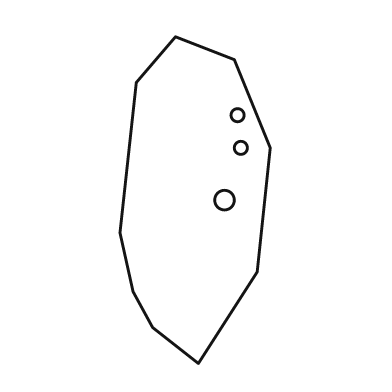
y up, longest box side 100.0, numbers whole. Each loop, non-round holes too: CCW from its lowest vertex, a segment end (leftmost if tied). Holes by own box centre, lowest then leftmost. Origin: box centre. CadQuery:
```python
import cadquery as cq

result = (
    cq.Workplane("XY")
    .moveTo(1.0, -50.0)
    .lineTo(19.0, -22.0)
    .lineTo(23.0, 16.0)
    .lineTo(12.0, 43.0)
    .lineTo(-6.0, 50.0)
    .lineTo(-18.0, 36.0)
    .lineTo(-23.0, -10.0)
    .lineTo(-19.0, -28.0)
    .lineTo(-13.0, -39.0)
    .close()
    .moveTo(9.0, 0.0)
    .circle(3.0)
    .moveTo(14.0, 16.0)
    .circle(2.0)
    .moveTo(13.0, 26.0)
    .circle(2.0)
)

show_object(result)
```